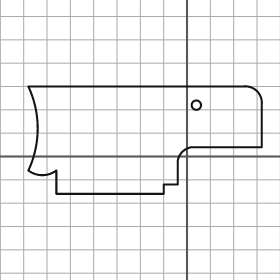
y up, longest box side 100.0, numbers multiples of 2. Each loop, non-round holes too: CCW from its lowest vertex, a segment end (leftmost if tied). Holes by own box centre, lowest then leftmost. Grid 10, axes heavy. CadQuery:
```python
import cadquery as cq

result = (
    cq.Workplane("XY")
    .moveTo(-56.0, -16.0)
    .lineTo(-10.0, -16.0)
    .lineTo(-10.0, -12.0)
    .lineTo(-4.0, -12.0)
    .lineTo(-4.0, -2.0)
    .threePointArc((-2.0, 2.0), (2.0, 4.0))
    .lineTo(32.0, 4.0)
    .lineTo(32.0, 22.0)
    .threePointArc((30.0, 28.0), (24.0, 30.0))
    .lineTo(-68.0, 30.0)
    .threePointArc((-64.0, 12.0), (-68.0, -6.0))
    .threePointArc((-62.0, -8.0), (-56.0, -6.0))
    .close()
    .moveTo(4.0, 22.0)
    .circle(2.0)
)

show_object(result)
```